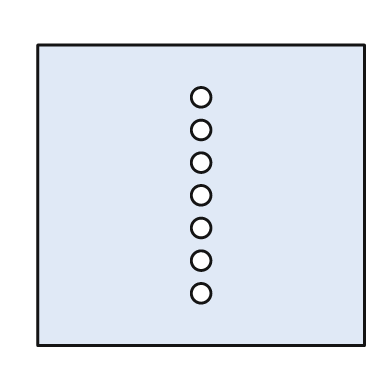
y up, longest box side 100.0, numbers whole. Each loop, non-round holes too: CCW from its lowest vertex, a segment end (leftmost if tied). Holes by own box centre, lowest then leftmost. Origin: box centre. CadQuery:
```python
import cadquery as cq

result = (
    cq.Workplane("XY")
    .moveTo(-50.0, -46.0)
    .lineTo(50.0, -46.0)
    .lineTo(50.0, 46.0)
    .lineTo(-50.0, 46.0)
    .close()
    .moveTo(0.0, -30.0)
    .circle(3.0)
    .moveTo(0.0, -20.0)
    .circle(3.0)
    .moveTo(0.0, -10.0)
    .circle(3.0)
    .moveTo(0.0, 0.0)
    .circle(3.0)
    .moveTo(0.0, 10.0)
    .circle(3.0)
    .moveTo(0.0, 20.0)
    .circle(3.0)
    .moveTo(0.0, 30.0)
    .circle(3.0)
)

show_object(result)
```